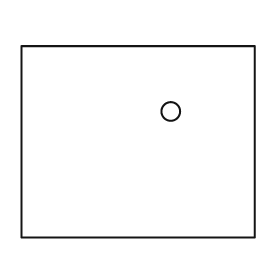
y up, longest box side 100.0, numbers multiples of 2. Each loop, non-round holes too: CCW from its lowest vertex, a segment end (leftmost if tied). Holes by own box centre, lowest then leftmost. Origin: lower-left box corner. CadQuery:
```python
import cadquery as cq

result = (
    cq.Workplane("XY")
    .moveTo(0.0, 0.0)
    .lineTo(100.0, 0.0)
    .lineTo(100.0, 82.0)
    .lineTo(0.0, 82.0)
    .close()
    .moveTo(64.0, 54.0)
    .circle(4.0)
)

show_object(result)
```